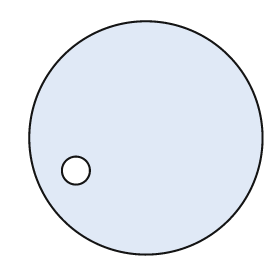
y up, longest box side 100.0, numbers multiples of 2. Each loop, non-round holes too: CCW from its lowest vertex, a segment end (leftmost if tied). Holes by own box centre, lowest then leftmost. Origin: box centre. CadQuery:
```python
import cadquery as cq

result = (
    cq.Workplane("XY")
    .moveTo(0.0, 0.0)
    .circle(50.0)
    .moveTo(-30.0, -14.0)
    .circle(6.0)
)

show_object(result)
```